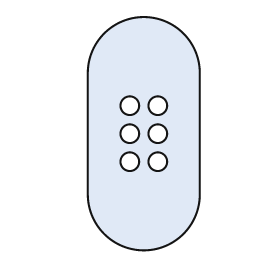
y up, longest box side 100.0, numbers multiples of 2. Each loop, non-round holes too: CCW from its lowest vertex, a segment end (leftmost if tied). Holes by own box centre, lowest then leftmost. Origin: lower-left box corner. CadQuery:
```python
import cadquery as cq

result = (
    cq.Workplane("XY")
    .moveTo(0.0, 24.0)
    .threePointArc((24.0, 0.0), (48.0, 24.0))
    .lineTo(48.0, 76.0)
    .threePointArc((24.0, 100.0), (0.0, 76.0))
    .close()
    .moveTo(18.0, 38.0)
    .circle(4.0)
    .moveTo(30.0, 38.0)
    .circle(4.0)
    .moveTo(18.0, 50.0)
    .circle(4.0)
    .moveTo(30.0, 50.0)
    .circle(4.0)
    .moveTo(18.0, 62.0)
    .circle(4.0)
    .moveTo(30.0, 62.0)
    .circle(4.0)
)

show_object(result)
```